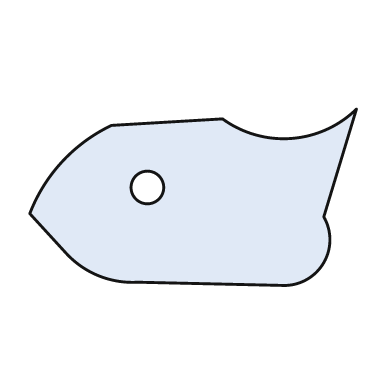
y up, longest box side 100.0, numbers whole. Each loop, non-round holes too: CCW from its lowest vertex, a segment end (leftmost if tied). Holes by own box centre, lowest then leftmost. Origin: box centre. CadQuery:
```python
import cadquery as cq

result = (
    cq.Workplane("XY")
    .moveTo(28.0, -27.0)
    .threePointArc((40.0, -20.0), (40.0, -6.0))
    .lineTo(50.0, 27.0)
    .threePointArc((30.0, 18.0), (9.0, 24.0))
    .lineTo(-25.0, 22.0)
    .threePointArc((-40.0, 11.0), (-50.0, -5.0))
    .lineTo(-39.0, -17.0)
    .threePointArc((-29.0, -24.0), (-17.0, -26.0))
    .close()
    .moveTo(-14.0, 3.0)
    .circle(5.0)
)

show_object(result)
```